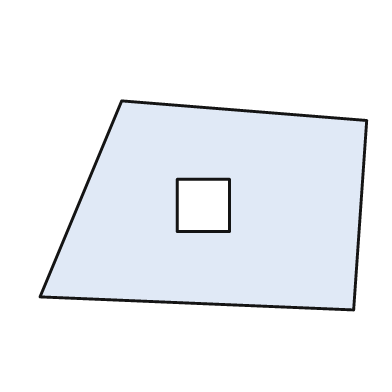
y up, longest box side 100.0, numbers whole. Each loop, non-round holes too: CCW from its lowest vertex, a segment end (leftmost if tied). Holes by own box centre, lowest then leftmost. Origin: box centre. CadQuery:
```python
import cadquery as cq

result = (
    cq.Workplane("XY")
    .moveTo(46.0, -32.0)
    .lineTo(50.0, 26.0)
    .lineTo(-25.0, 32.0)
    .lineTo(-50.0, -28.0)
    .close()
    .moveTo(-8.0, -8.0)
    .lineTo(8.0, -8.0)
    .lineTo(8.0, 8.0)
    .lineTo(-8.0, 8.0)
    .close()
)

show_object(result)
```